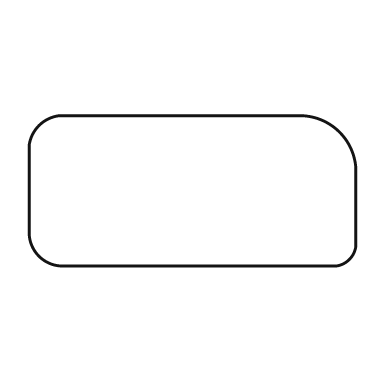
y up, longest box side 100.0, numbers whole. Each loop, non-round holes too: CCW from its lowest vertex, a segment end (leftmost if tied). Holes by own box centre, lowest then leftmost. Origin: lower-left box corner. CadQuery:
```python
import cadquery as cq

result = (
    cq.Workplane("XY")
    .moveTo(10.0, 0.0)
    .lineTo(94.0, 0.0)
    .threePointArc((98.0, 2.0), (100.0, 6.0))
    .lineTo(100.0, 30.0)
    .threePointArc((95.0, 41.0), (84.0, 46.0))
    .lineTo(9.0, 46.0)
    .threePointArc((3.0, 43.0), (0.0, 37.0))
    .lineTo(0.0, 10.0)
    .threePointArc((3.0, 3.0), (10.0, 0.0))
    .close()
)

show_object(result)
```